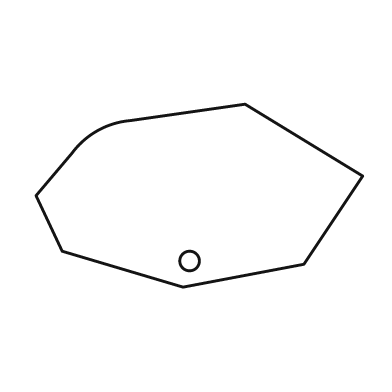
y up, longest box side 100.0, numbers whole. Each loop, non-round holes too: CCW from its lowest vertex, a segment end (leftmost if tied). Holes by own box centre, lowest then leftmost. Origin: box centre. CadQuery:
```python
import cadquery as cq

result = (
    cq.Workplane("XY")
    .moveTo(-5.0, -28.0)
    .lineTo(32.0, -21.0)
    .lineTo(50.0, 6.0)
    .lineTo(14.0, 28.0)
    .lineTo(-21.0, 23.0)
    .threePointArc((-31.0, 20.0), (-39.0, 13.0))
    .lineTo(-50.0, 0.0)
    .lineTo(-42.0, -17.0)
    .close()
    .moveTo(-3.0, -20.0)
    .circle(3.0)
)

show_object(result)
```